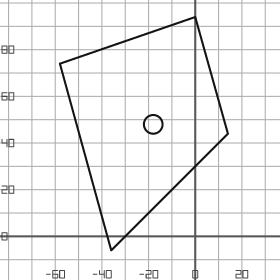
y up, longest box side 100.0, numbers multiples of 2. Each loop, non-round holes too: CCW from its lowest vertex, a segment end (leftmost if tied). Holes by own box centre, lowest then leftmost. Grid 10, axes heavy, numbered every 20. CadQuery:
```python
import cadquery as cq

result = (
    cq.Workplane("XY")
    .moveTo(-36.0, -6.0)
    .lineTo(14.0, 44.0)
    .lineTo(0.0, 94.0)
    .lineTo(-58.0, 74.0)
    .close()
    .moveTo(-18.0, 48.0)
    .circle(4.0)
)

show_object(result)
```